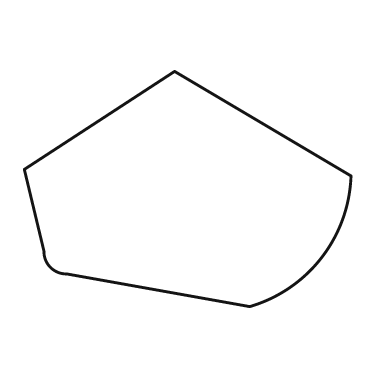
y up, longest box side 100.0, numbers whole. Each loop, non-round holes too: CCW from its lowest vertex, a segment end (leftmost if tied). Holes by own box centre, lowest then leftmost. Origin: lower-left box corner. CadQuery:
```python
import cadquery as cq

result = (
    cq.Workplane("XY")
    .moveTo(69.0, 0.0)
    .threePointArc((91.0, 15.0), (100.0, 40.0))
    .lineTo(46.0, 72.0)
    .lineTo(0.0, 42.0)
    .lineTo(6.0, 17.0)
    .threePointArc((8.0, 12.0), (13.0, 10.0))
    .close()
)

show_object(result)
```